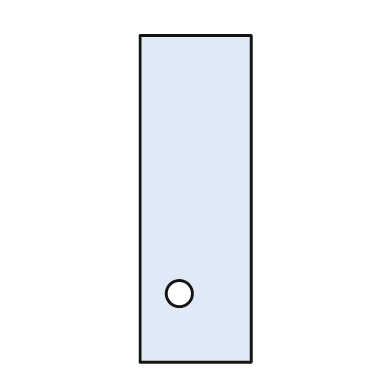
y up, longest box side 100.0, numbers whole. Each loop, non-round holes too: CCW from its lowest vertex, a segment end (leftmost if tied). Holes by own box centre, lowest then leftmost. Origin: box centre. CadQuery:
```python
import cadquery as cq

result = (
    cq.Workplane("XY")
    .moveTo(-17.0, -50.0)
    .lineTo(17.0, -50.0)
    .lineTo(17.0, 50.0)
    .lineTo(-17.0, 50.0)
    .close()
    .moveTo(-5.0, -29.0)
    .circle(4.0)
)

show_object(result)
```